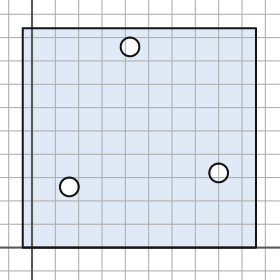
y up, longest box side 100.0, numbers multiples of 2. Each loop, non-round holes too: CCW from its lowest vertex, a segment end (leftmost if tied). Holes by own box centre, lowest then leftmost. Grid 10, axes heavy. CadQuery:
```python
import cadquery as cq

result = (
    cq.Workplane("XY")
    .moveTo(-4.0, 0.0)
    .lineTo(96.0, 0.0)
    .lineTo(96.0, 94.0)
    .lineTo(-4.0, 94.0)
    .close()
    .moveTo(16.0, 26.0)
    .circle(4.0)
    .moveTo(80.0, 32.0)
    .circle(4.0)
    .moveTo(42.0, 86.0)
    .circle(4.0)
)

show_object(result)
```